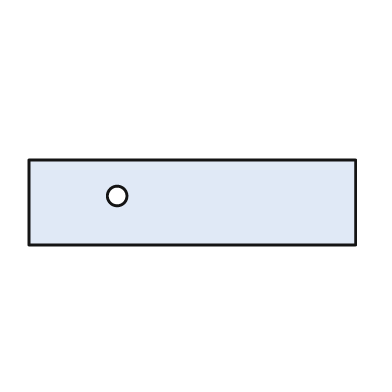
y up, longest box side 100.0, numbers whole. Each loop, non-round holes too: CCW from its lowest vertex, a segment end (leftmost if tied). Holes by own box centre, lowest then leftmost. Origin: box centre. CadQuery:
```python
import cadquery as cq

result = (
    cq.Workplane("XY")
    .moveTo(-50.0, -13.0)
    .lineTo(50.0, -13.0)
    .lineTo(50.0, 13.0)
    .lineTo(-50.0, 13.0)
    .close()
    .moveTo(-23.0, 2.0)
    .circle(3.0)
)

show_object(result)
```